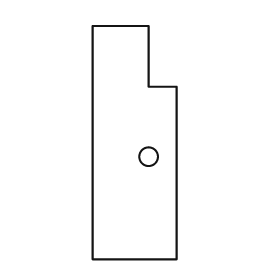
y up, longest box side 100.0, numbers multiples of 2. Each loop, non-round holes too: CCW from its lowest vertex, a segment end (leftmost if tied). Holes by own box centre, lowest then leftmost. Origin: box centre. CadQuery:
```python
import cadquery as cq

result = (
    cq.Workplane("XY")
    .moveTo(-18.0, -50.0)
    .lineTo(18.0, -50.0)
    .lineTo(18.0, 24.0)
    .lineTo(6.0, 24.0)
    .lineTo(6.0, 50.0)
    .lineTo(-18.0, 50.0)
    .close()
    .moveTo(6.0, -6.0)
    .circle(4.0)
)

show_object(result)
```